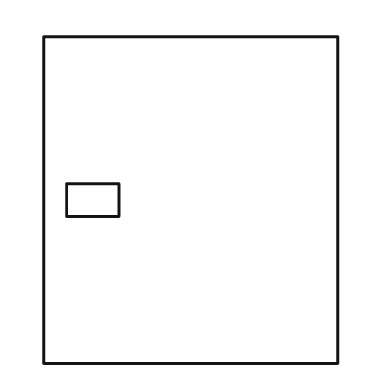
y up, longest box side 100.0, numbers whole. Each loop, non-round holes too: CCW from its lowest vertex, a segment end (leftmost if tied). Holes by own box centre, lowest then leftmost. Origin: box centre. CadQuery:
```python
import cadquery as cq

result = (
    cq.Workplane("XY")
    .moveTo(-45.0, -50.0)
    .lineTo(45.0, -50.0)
    .lineTo(45.0, 50.0)
    .lineTo(-45.0, 50.0)
    .close()
    .moveTo(-38.0, -5.0)
    .lineTo(-22.0, -5.0)
    .lineTo(-22.0, 5.0)
    .lineTo(-38.0, 5.0)
    .close()
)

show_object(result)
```